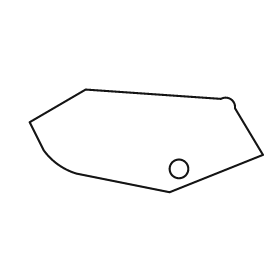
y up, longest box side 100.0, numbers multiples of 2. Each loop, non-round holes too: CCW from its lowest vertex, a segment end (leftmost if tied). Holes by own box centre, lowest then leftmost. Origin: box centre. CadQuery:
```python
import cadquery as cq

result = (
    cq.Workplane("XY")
    .moveTo(10.0, -22.0)
    .lineTo(50.0, -6.0)
    .lineTo(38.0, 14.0)
    .threePointArc((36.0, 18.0), (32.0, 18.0))
    .lineTo(-26.0, 22.0)
    .lineTo(-50.0, 8.0)
    .lineTo(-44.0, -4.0)
    .threePointArc((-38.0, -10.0), (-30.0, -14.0))
    .close()
    .moveTo(14.0, -12.0)
    .circle(4.0)
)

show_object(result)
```